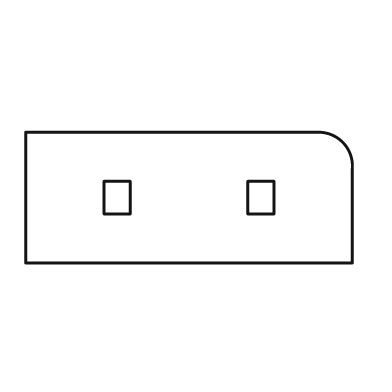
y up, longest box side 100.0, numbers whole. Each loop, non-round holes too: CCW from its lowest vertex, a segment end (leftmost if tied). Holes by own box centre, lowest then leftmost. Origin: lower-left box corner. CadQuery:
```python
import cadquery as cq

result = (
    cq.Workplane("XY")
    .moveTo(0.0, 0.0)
    .lineTo(100.0, 0.0)
    .lineTo(100.0, 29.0)
    .threePointArc((97.0, 37.0), (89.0, 40.0))
    .lineTo(0.0, 40.0)
    .close()
    .moveTo(24.0, 15.0)
    .lineTo(32.0, 15.0)
    .lineTo(32.0, 25.0)
    .lineTo(24.0, 25.0)
    .close()
    .moveTo(68.0, 15.0)
    .lineTo(76.0, 15.0)
    .lineTo(76.0, 25.0)
    .lineTo(68.0, 25.0)
    .close()
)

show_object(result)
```